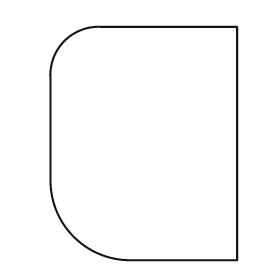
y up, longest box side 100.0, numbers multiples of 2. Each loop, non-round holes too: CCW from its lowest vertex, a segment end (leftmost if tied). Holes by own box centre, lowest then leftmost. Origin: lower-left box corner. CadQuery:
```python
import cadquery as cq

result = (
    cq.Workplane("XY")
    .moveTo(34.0, 0.0)
    .lineTo(80.0, 0.0)
    .lineTo(80.0, 100.0)
    .lineTo(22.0, 100.0)
    .threePointArc((6.0, 94.0), (0.0, 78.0))
    .lineTo(0.0, 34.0)
    .threePointArc((10.0, 10.0), (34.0, 0.0))
    .close()
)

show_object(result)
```